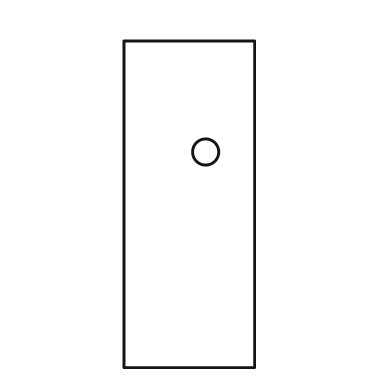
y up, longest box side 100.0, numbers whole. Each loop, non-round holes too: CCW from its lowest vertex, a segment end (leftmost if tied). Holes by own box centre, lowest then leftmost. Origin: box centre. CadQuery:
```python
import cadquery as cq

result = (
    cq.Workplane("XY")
    .moveTo(-20.0, -50.0)
    .lineTo(20.0, -50.0)
    .lineTo(20.0, 50.0)
    .lineTo(-20.0, 50.0)
    .close()
    .moveTo(5.0, 16.0)
    .circle(4.0)
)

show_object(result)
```